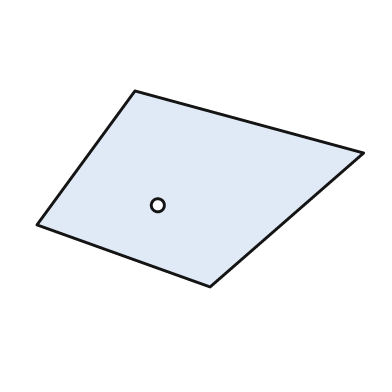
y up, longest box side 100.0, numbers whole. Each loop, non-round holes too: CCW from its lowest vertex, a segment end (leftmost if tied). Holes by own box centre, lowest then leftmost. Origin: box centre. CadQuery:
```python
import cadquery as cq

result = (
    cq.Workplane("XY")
    .moveTo(3.0, -30.0)
    .lineTo(50.0, 11.0)
    .lineTo(-20.0, 30.0)
    .lineTo(-50.0, -11.0)
    .close()
    .moveTo(-13.0, -5.0)
    .circle(2.0)
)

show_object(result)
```